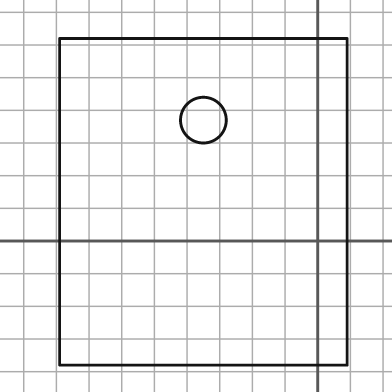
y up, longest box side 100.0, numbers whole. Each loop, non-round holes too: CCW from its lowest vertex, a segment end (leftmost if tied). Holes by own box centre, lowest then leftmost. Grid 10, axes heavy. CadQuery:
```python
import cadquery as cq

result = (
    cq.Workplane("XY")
    .moveTo(-79.0, -38.0)
    .lineTo(9.0, -38.0)
    .lineTo(9.0, 62.0)
    .lineTo(-79.0, 62.0)
    .close()
    .moveTo(-35.0, 37.0)
    .circle(7.0)
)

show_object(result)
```